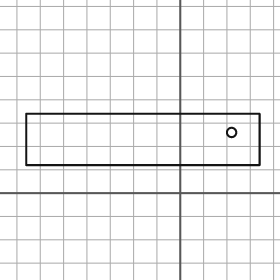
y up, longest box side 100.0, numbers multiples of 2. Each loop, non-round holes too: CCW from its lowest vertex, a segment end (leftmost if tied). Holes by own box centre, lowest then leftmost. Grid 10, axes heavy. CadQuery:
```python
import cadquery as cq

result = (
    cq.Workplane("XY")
    .moveTo(-66.0, 12.0)
    .lineTo(34.0, 12.0)
    .lineTo(34.0, 34.0)
    .lineTo(-66.0, 34.0)
    .close()
    .moveTo(22.0, 26.0)
    .circle(2.0)
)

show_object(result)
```